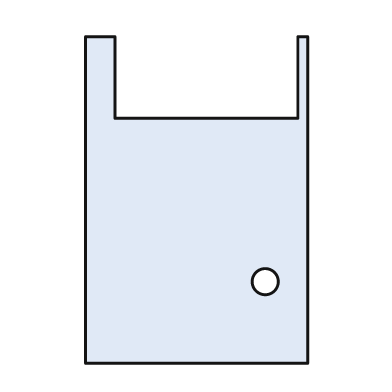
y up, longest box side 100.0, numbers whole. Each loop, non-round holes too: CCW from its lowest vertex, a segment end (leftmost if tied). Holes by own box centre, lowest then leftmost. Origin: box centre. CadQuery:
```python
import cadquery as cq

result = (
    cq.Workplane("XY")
    .moveTo(-34.0, -50.0)
    .lineTo(34.0, -50.0)
    .lineTo(34.0, 50.0)
    .lineTo(31.0, 50.0)
    .lineTo(31.0, 25.0)
    .lineTo(-25.0, 25.0)
    .lineTo(-25.0, 50.0)
    .lineTo(-34.0, 50.0)
    .close()
    .moveTo(21.0, -25.0)
    .circle(4.0)
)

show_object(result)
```